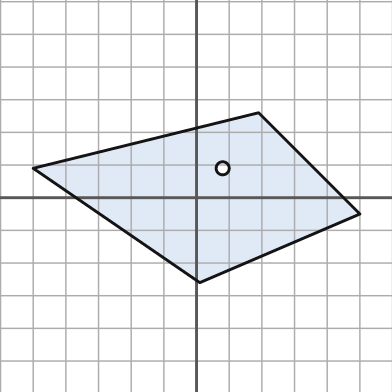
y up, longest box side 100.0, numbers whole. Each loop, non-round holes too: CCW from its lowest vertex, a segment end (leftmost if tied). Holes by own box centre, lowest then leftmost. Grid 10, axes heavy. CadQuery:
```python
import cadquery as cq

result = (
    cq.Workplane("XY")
    .moveTo(1.0, -26.0)
    .lineTo(50.0, -5.0)
    .lineTo(19.0, 26.0)
    .lineTo(-50.0, 9.0)
    .close()
    .moveTo(8.0, 9.0)
    .circle(2.0)
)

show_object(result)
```